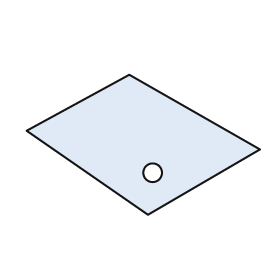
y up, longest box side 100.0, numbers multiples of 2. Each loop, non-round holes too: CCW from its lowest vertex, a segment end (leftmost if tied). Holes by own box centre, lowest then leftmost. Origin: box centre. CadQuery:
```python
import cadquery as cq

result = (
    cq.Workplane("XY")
    .moveTo(2.0, -30.0)
    .lineTo(50.0, -2.0)
    .lineTo(-6.0, 30.0)
    .lineTo(-50.0, 6.0)
    .close()
    .moveTo(4.0, -12.0)
    .circle(4.0)
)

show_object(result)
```